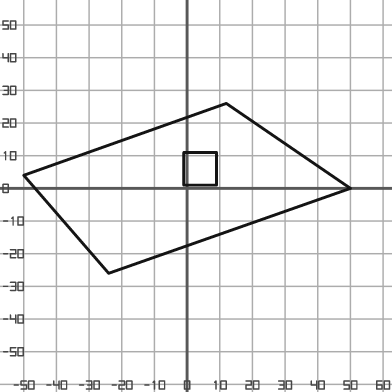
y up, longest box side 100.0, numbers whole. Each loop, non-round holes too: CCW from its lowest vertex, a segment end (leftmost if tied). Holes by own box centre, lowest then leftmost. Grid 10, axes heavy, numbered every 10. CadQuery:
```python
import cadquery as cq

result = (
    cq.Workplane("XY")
    .moveTo(-24.0, -26.0)
    .lineTo(50.0, 0.0)
    .lineTo(12.0, 26.0)
    .lineTo(-50.0, 4.0)
    .close()
    .moveTo(-1.0, 1.0)
    .lineTo(9.0, 1.0)
    .lineTo(9.0, 11.0)
    .lineTo(-1.0, 11.0)
    .close()
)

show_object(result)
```